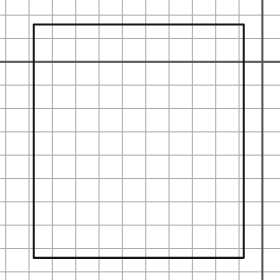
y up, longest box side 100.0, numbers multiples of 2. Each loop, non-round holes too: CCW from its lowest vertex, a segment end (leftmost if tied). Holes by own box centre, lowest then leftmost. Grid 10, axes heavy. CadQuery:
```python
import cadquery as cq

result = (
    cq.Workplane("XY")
    .moveTo(-98.0, -84.0)
    .lineTo(-8.0, -84.0)
    .lineTo(-8.0, 16.0)
    .lineTo(-98.0, 16.0)
    .close()
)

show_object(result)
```